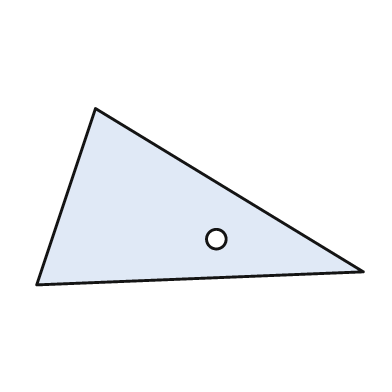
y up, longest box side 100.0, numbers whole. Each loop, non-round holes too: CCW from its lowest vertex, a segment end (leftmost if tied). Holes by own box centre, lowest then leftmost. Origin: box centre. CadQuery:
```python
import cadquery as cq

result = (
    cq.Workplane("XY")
    .moveTo(-50.0, -27.0)
    .lineTo(50.0, -23.0)
    .lineTo(-32.0, 27.0)
    .close()
    .moveTo(5.0, -13.0)
    .circle(3.0)
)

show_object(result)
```